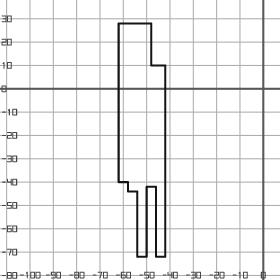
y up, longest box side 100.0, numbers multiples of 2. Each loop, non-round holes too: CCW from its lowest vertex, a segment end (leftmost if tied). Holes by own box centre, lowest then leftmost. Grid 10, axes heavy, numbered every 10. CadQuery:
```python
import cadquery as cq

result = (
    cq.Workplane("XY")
    .moveTo(-54.0, -72.0)
    .lineTo(-50.0, -72.0)
    .lineTo(-50.0, -42.0)
    .lineTo(-46.0, -42.0)
    .lineTo(-46.0, -72.0)
    .lineTo(-42.0, -72.0)
    .lineTo(-42.0, 10.0)
    .lineTo(-48.0, 10.0)
    .lineTo(-48.0, 28.0)
    .lineTo(-62.0, 28.0)
    .lineTo(-62.0, -40.0)
    .lineTo(-58.0, -40.0)
    .lineTo(-58.0, -44.0)
    .lineTo(-54.0, -44.0)
    .close()
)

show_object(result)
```